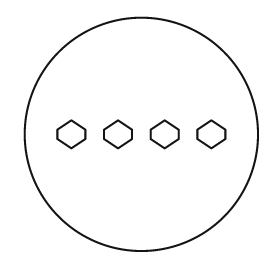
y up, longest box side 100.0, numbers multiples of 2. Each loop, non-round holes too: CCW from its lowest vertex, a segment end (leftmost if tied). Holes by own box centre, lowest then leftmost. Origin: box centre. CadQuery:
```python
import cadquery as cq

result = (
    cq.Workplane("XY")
    .moveTo(0.0, 0.0)
    .circle(50.0)
    .moveTo(-30.0, -6.0)
    .lineTo(-24.0, -2.0)
    .lineTo(-24.0, 2.0)
    .lineTo(-30.0, 6.0)
    .lineTo(-36.0, 2.0)
    .lineTo(-36.0, -2.0)
    .close()
    .moveTo(-10.0, -6.0)
    .lineTo(-4.0, -2.0)
    .lineTo(-4.0, 2.0)
    .lineTo(-10.0, 6.0)
    .lineTo(-16.0, 2.0)
    .lineTo(-16.0, -2.0)
    .close()
    .moveTo(10.0, -6.0)
    .lineTo(16.0, -2.0)
    .lineTo(16.0, 2.0)
    .lineTo(10.0, 6.0)
    .lineTo(4.0, 2.0)
    .lineTo(4.0, -2.0)
    .close()
    .moveTo(30.0, -6.0)
    .lineTo(36.0, -2.0)
    .lineTo(36.0, 2.0)
    .lineTo(30.0, 6.0)
    .lineTo(24.0, 2.0)
    .lineTo(24.0, -2.0)
    .close()
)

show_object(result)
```